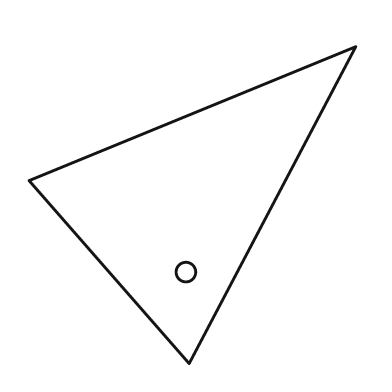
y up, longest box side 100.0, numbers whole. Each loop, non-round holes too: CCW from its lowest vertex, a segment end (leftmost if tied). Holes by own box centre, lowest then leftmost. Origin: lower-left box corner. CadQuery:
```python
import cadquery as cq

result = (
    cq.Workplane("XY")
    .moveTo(49.0, 0.0)
    .lineTo(100.0, 97.0)
    .lineTo(0.0, 56.0)
    .close()
    .moveTo(48.0, 28.0)
    .circle(3.0)
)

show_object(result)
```